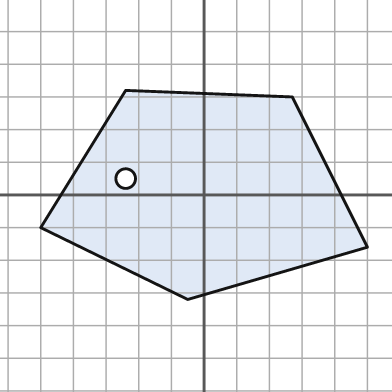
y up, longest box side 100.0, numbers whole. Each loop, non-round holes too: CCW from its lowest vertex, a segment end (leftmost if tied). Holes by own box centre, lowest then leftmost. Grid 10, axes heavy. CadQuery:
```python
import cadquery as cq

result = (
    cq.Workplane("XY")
    .moveTo(-5.0, -32.0)
    .lineTo(50.0, -16.0)
    .lineTo(27.0, 30.0)
    .lineTo(-24.0, 32.0)
    .lineTo(-50.0, -10.0)
    .close()
    .moveTo(-24.0, 5.0)
    .circle(3.0)
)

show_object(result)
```